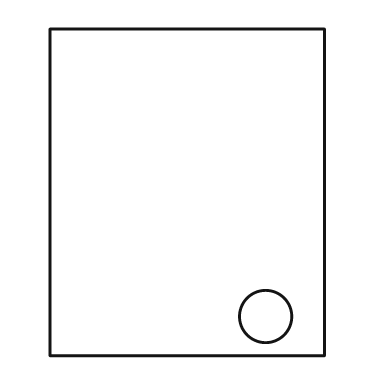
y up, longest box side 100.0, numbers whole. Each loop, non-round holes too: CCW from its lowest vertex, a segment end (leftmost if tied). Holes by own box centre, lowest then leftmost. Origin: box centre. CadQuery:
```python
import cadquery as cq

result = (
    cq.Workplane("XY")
    .moveTo(-42.0, -50.0)
    .lineTo(42.0, -50.0)
    .lineTo(42.0, 50.0)
    .lineTo(-42.0, 50.0)
    .close()
    .moveTo(24.0, -38.0)
    .circle(8.0)
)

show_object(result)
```